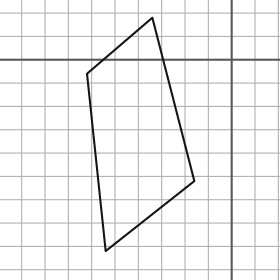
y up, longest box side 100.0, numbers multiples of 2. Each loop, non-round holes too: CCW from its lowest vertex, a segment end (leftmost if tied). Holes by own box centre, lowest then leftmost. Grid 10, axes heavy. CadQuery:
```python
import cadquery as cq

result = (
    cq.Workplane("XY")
    .moveTo(-54.0, -82.0)
    .lineTo(-16.0, -52.0)
    .lineTo(-34.0, 18.0)
    .lineTo(-62.0, -6.0)
    .close()
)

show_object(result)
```